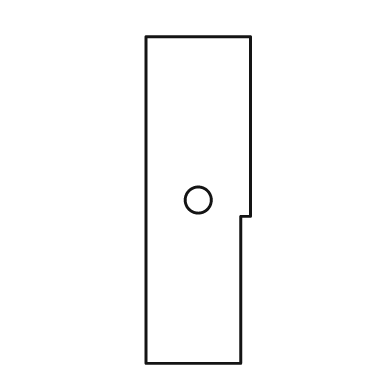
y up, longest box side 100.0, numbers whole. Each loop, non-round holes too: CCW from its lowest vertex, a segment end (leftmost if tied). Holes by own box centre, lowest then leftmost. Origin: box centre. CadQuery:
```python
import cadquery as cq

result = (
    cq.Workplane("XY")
    .moveTo(-16.0, -50.0)
    .lineTo(13.0, -50.0)
    .lineTo(13.0, -5.0)
    .lineTo(16.0, -5.0)
    .lineTo(16.0, 50.0)
    .lineTo(-16.0, 50.0)
    .close()
    .moveTo(0.0, 0.0)
    .circle(4.0)
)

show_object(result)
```